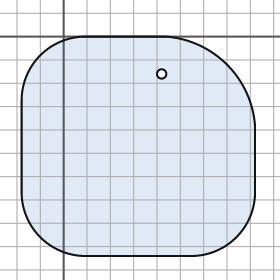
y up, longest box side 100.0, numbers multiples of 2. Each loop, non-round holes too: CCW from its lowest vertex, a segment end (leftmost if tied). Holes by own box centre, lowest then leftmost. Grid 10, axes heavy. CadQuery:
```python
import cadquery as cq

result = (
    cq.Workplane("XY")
    .moveTo(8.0, -94.0)
    .lineTo(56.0, -94.0)
    .threePointArc((74.0, -86.0), (82.0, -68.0))
    .lineTo(82.0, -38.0)
    .threePointArc((70.0, -12.0), (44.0, 0.0))
    .lineTo(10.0, 0.0)
    .threePointArc((-10.0, -8.0), (-18.0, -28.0))
    .lineTo(-18.0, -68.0)
    .threePointArc((-10.0, -86.0), (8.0, -94.0))
    .close()
    .moveTo(42.0, -16.0)
    .circle(2.0)
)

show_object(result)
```